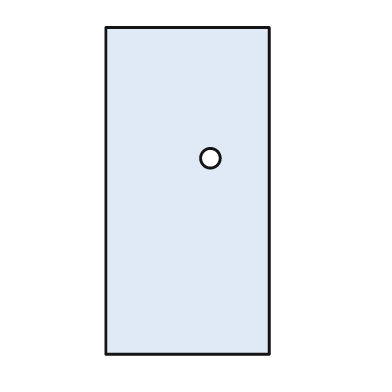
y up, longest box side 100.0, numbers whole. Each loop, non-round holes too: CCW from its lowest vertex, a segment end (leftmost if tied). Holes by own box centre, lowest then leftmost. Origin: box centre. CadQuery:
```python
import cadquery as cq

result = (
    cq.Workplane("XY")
    .moveTo(-25.0, -50.0)
    .lineTo(25.0, -50.0)
    .lineTo(25.0, 50.0)
    .lineTo(-25.0, 50.0)
    .close()
    .moveTo(7.0, 10.0)
    .circle(3.0)
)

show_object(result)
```